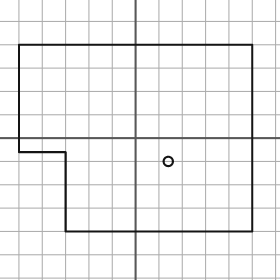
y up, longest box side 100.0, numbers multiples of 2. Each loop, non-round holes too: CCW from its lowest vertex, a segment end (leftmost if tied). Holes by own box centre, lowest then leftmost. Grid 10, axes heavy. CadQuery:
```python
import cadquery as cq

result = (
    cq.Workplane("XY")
    .moveTo(-30.0, -40.0)
    .lineTo(50.0, -40.0)
    .lineTo(50.0, 40.0)
    .lineTo(-50.0, 40.0)
    .lineTo(-50.0, -6.0)
    .lineTo(-30.0, -6.0)
    .close()
    .moveTo(14.0, -10.0)
    .circle(2.0)
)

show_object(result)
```